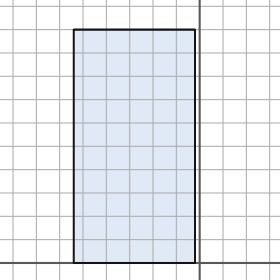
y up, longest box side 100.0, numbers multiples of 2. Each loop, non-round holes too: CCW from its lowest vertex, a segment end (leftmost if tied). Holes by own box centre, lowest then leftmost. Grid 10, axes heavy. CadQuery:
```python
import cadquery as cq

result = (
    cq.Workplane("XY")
    .moveTo(-54.0, 0.0)
    .lineTo(-2.0, 0.0)
    .lineTo(-2.0, 100.0)
    .lineTo(-54.0, 100.0)
    .close()
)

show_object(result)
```